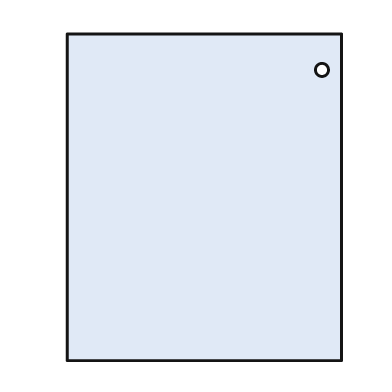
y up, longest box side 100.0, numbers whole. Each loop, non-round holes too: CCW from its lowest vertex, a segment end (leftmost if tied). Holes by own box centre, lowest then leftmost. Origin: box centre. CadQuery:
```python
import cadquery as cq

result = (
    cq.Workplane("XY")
    .moveTo(-42.0, -50.0)
    .lineTo(42.0, -50.0)
    .lineTo(42.0, 50.0)
    .lineTo(-42.0, 50.0)
    .close()
    .moveTo(36.0, 39.0)
    .circle(2.0)
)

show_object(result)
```